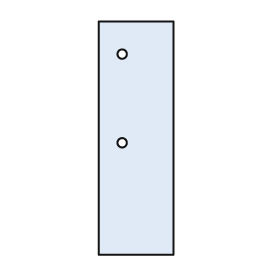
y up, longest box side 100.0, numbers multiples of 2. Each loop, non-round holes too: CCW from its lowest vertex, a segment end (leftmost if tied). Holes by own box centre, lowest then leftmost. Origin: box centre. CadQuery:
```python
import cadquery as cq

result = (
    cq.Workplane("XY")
    .moveTo(-16.0, -50.0)
    .lineTo(16.0, -50.0)
    .lineTo(16.0, 50.0)
    .lineTo(-16.0, 50.0)
    .close()
    .moveTo(-6.0, -2.0)
    .circle(2.0)
    .moveTo(-6.0, 36.0)
    .circle(2.0)
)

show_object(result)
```